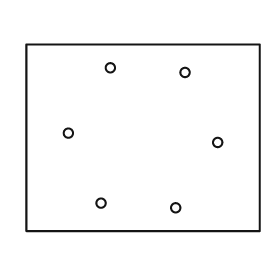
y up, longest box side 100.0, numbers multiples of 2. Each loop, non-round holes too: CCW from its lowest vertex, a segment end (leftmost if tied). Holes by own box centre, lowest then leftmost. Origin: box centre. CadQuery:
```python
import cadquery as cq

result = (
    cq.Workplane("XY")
    .moveTo(-50.0, -40.0)
    .lineTo(50.0, -40.0)
    .lineTo(50.0, 40.0)
    .lineTo(-50.0, 40.0)
    .close()
    .moveTo(14.0, -30.0)
    .circle(2.0)
    .moveTo(-18.0, -28.0)
    .circle(2.0)
    .moveTo(32.0, -2.0)
    .circle(2.0)
    .moveTo(-32.0, 2.0)
    .circle(2.0)
    .moveTo(18.0, 28.0)
    .circle(2.0)
    .moveTo(-14.0, 30.0)
    .circle(2.0)
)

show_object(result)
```